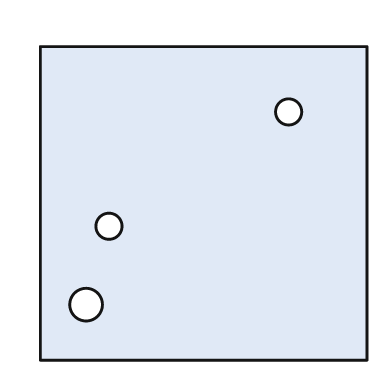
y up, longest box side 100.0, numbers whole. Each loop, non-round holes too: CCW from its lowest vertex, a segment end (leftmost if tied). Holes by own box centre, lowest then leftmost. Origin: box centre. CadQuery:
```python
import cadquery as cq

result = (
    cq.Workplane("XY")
    .moveTo(-50.0, -48.0)
    .lineTo(50.0, -48.0)
    .lineTo(50.0, 48.0)
    .lineTo(-50.0, 48.0)
    .close()
    .moveTo(-36.0, -31.0)
    .circle(5.0)
    .moveTo(-29.0, -7.0)
    .circle(4.0)
    .moveTo(26.0, 28.0)
    .circle(4.0)
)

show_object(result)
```